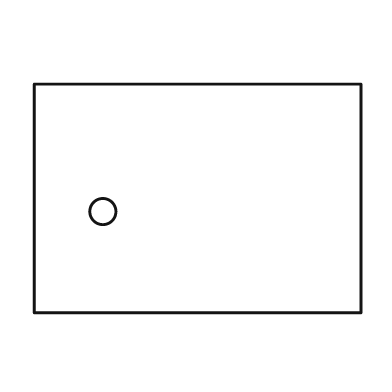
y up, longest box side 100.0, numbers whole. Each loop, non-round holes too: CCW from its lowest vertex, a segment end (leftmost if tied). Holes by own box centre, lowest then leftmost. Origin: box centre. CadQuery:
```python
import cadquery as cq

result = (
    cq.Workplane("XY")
    .moveTo(-50.0, -35.0)
    .lineTo(50.0, -35.0)
    .lineTo(50.0, 35.0)
    .lineTo(-50.0, 35.0)
    .close()
    .moveTo(-29.0, -4.0)
    .circle(4.0)
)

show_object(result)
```